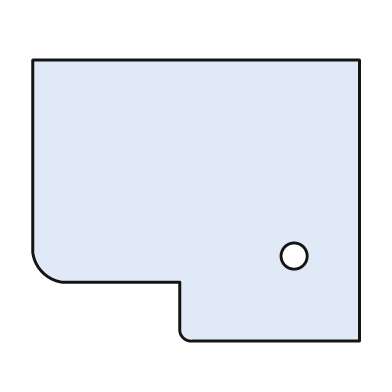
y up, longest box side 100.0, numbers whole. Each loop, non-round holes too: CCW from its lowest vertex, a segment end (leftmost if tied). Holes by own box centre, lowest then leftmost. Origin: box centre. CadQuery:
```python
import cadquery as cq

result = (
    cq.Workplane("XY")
    .moveTo(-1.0, -43.0)
    .lineTo(50.0, -43.0)
    .lineTo(50.0, 43.0)
    .lineTo(-50.0, 43.0)
    .lineTo(-50.0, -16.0)
    .threePointArc((-47.0, -22.0), (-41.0, -25.0))
    .lineTo(-5.0, -25.0)
    .lineTo(-5.0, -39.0)
    .threePointArc((-4.0, -42.0), (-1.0, -43.0))
    .close()
    .moveTo(30.0, -17.0)
    .circle(4.0)
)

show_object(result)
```